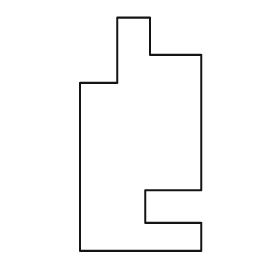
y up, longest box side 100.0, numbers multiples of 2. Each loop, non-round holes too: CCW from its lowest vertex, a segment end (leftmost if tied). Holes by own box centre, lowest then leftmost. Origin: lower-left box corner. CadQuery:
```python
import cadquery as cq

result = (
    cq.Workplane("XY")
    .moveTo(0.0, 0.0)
    .lineTo(52.0, 0.0)
    .lineTo(52.0, 12.0)
    .lineTo(28.0, 12.0)
    .lineTo(28.0, 26.0)
    .lineTo(52.0, 26.0)
    .lineTo(52.0, 84.0)
    .lineTo(30.0, 84.0)
    .lineTo(30.0, 100.0)
    .lineTo(16.0, 100.0)
    .lineTo(16.0, 72.0)
    .lineTo(0.0, 72.0)
    .close()
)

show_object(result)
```